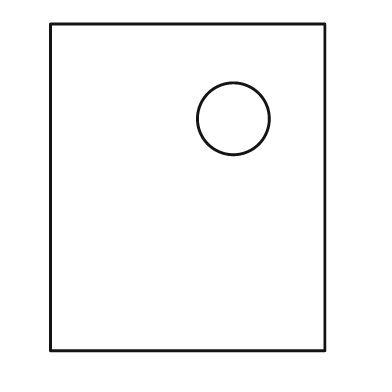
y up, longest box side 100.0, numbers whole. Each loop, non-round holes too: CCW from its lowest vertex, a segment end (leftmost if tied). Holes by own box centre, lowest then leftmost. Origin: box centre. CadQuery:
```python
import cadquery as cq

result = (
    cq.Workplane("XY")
    .moveTo(-42.0, -50.0)
    .lineTo(42.0, -50.0)
    .lineTo(42.0, 50.0)
    .lineTo(-42.0, 50.0)
    .close()
    .moveTo(14.0, 21.0)
    .circle(11.0)
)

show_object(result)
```